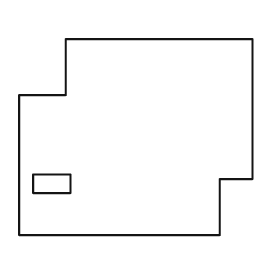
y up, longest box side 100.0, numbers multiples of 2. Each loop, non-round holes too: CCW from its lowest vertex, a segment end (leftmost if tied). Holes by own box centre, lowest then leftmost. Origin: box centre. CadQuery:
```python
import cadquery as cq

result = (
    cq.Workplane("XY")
    .moveTo(-50.0, -42.0)
    .lineTo(36.0, -42.0)
    .lineTo(36.0, -18.0)
    .lineTo(50.0, -18.0)
    .lineTo(50.0, 42.0)
    .lineTo(-30.0, 42.0)
    .lineTo(-30.0, 18.0)
    .lineTo(-50.0, 18.0)
    .close()
    .moveTo(-44.0, -24.0)
    .lineTo(-28.0, -24.0)
    .lineTo(-28.0, -16.0)
    .lineTo(-44.0, -16.0)
    .close()
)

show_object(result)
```